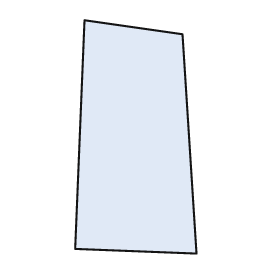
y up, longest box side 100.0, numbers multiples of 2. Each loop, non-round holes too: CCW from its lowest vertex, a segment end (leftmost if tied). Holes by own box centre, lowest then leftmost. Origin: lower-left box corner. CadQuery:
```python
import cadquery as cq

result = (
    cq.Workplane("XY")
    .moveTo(52.0, 0.0)
    .lineTo(46.0, 94.0)
    .lineTo(4.0, 100.0)
    .lineTo(0.0, 2.0)
    .close()
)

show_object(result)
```